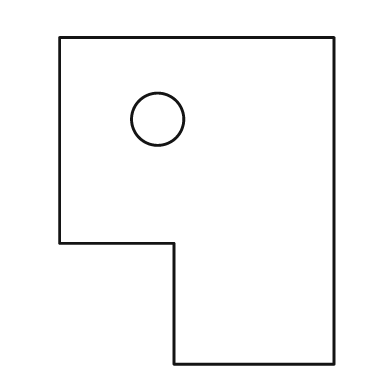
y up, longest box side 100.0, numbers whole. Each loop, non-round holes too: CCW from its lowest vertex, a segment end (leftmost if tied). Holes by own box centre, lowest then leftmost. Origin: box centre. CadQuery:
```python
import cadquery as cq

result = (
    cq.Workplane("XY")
    .moveTo(-7.0, -50.0)
    .lineTo(42.0, -50.0)
    .lineTo(42.0, 50.0)
    .lineTo(-42.0, 50.0)
    .lineTo(-42.0, -13.0)
    .lineTo(-7.0, -13.0)
    .close()
    .moveTo(-12.0, 25.0)
    .circle(8.0)
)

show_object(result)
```